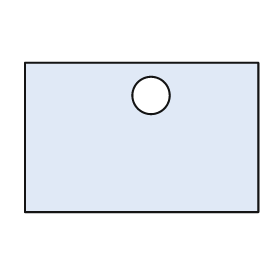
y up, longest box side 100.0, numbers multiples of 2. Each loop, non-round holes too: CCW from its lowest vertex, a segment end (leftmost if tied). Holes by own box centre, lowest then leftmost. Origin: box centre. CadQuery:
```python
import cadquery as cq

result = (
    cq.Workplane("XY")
    .moveTo(-50.0, -32.0)
    .lineTo(50.0, -32.0)
    .lineTo(50.0, 32.0)
    .lineTo(-50.0, 32.0)
    .close()
    .moveTo(4.0, 18.0)
    .circle(8.0)
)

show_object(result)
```